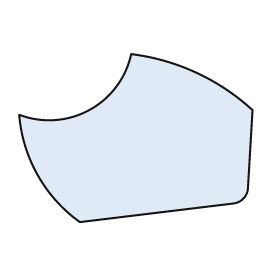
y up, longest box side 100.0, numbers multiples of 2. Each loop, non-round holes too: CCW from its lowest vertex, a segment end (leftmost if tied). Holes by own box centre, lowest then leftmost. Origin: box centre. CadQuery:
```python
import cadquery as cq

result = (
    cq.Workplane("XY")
    .moveTo(-24.0, -36.0)
    .lineTo(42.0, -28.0)
    .threePointArc((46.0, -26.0), (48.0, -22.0))
    .lineTo(50.0, 12.0)
    .threePointArc((26.0, 28.0), (-2.0, 36.0))
    .threePointArc((-20.0, 12.0), (-50.0, 10.0))
    .threePointArc((-42.0, -16.0), (-24.0, -36.0))
    .close()
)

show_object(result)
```